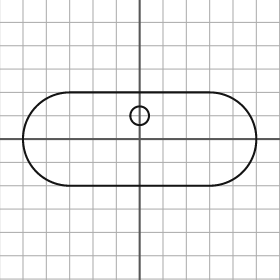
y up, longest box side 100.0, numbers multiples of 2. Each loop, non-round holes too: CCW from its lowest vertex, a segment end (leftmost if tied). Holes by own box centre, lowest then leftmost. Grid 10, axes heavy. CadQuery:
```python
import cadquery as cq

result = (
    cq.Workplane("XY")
    .moveTo(-30.0, -20.0)
    .lineTo(30.0, -20.0)
    .threePointArc((50.0, 0.0), (30.0, 20.0))
    .lineTo(-30.0, 20.0)
    .threePointArc((-50.0, 0.0), (-30.0, -20.0))
    .close()
    .moveTo(0.0, 10.0)
    .circle(4.0)
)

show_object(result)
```